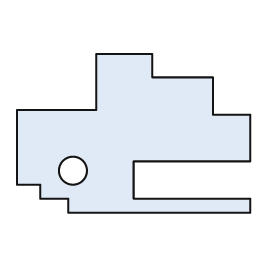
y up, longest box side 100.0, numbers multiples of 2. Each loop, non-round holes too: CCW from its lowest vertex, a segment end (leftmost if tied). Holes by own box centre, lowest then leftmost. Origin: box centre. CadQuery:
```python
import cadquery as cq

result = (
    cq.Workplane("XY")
    .moveTo(-28.0, -34.0)
    .lineTo(50.0, -34.0)
    .lineTo(50.0, -28.0)
    .lineTo(0.0, -28.0)
    .lineTo(0.0, -12.0)
    .lineTo(50.0, -12.0)
    .lineTo(50.0, 8.0)
    .lineTo(34.0, 8.0)
    .lineTo(34.0, 24.0)
    .lineTo(8.0, 24.0)
    .lineTo(8.0, 34.0)
    .lineTo(-16.0, 34.0)
    .lineTo(-16.0, 10.0)
    .lineTo(-50.0, 10.0)
    .lineTo(-50.0, -22.0)
    .lineTo(-40.0, -22.0)
    .lineTo(-40.0, -28.0)
    .lineTo(-28.0, -28.0)
    .close()
    .moveTo(-26.0, -16.0)
    .circle(6.0)
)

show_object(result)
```